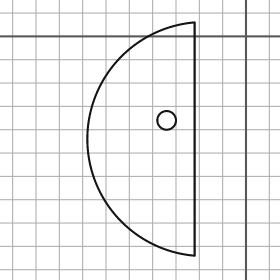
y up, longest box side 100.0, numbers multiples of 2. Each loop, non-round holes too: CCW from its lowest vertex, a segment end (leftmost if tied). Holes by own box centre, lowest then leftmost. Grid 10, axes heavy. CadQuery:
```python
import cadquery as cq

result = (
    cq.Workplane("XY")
    .moveTo(-22.0, -94.0)
    .lineTo(-22.0, 6.0)
    .threePointArc((-68.0, -44.0), (-22.0, -94.0))
    .close()
    .moveTo(-34.0, -36.0)
    .circle(4.0)
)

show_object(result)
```